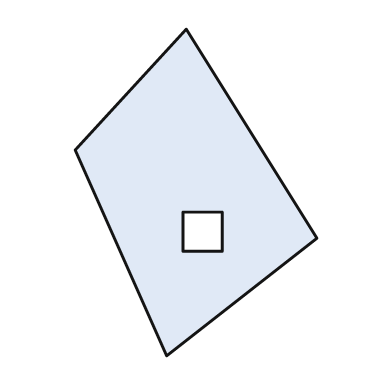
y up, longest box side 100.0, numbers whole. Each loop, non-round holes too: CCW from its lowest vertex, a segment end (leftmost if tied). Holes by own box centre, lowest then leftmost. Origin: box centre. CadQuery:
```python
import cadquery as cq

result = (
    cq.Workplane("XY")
    .moveTo(-9.0, -50.0)
    .lineTo(37.0, -14.0)
    .lineTo(-3.0, 50.0)
    .lineTo(-37.0, 13.0)
    .close()
    .moveTo(-4.0, -18.0)
    .lineTo(8.0, -18.0)
    .lineTo(8.0, -6.0)
    .lineTo(-4.0, -6.0)
    .close()
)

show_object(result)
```